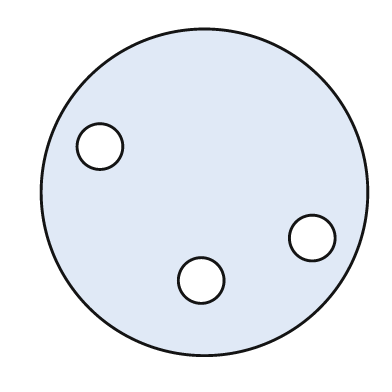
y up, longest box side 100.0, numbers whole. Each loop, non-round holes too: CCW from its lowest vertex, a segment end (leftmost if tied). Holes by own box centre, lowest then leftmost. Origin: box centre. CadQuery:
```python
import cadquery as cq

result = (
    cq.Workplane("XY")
    .moveTo(0.0, 0.0)
    .circle(50.0)
    .moveTo(-1.0, -27.0)
    .circle(7.0)
    .moveTo(33.0, -14.0)
    .circle(7.0)
    .moveTo(-32.0, 14.0)
    .circle(7.0)
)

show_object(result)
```